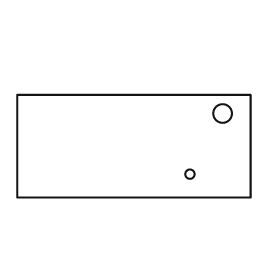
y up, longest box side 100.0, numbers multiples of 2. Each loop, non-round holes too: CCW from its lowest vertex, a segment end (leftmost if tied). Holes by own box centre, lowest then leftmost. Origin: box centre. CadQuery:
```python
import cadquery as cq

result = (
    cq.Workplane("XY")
    .moveTo(-50.0, -22.0)
    .lineTo(50.0, -22.0)
    .lineTo(50.0, 22.0)
    .lineTo(-50.0, 22.0)
    .close()
    .moveTo(24.0, -12.0)
    .circle(2.0)
    .moveTo(38.0, 14.0)
    .circle(4.0)
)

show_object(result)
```